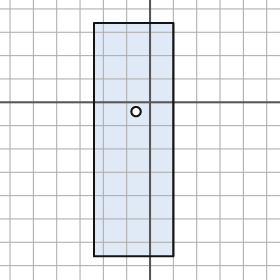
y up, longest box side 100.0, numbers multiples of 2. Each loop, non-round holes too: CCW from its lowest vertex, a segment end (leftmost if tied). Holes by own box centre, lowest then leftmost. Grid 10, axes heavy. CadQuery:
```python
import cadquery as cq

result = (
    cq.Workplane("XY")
    .moveTo(-24.0, -66.0)
    .lineTo(10.0, -66.0)
    .lineTo(10.0, 34.0)
    .lineTo(-24.0, 34.0)
    .close()
    .moveTo(-6.0, -4.0)
    .circle(2.0)
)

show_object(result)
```